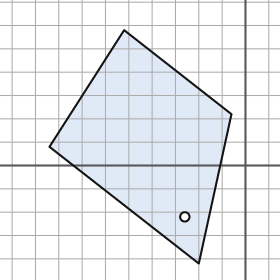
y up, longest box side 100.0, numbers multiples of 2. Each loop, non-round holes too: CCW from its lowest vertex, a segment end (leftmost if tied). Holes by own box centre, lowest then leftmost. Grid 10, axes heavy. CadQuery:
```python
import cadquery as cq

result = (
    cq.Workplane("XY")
    .moveTo(-20.0, -42.0)
    .lineTo(-6.0, 22.0)
    .lineTo(-52.0, 58.0)
    .lineTo(-84.0, 8.0)
    .close()
    .moveTo(-26.0, -22.0)
    .circle(2.0)
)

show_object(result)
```